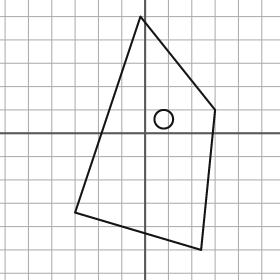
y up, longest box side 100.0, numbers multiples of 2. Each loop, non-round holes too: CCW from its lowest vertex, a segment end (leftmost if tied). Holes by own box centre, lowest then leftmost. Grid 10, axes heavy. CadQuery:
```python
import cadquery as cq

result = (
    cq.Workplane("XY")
    .moveTo(24.0, -50.0)
    .lineTo(30.0, 10.0)
    .lineTo(-2.0, 50.0)
    .lineTo(-30.0, -34.0)
    .close()
    .moveTo(8.0, 6.0)
    .circle(4.0)
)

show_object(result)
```